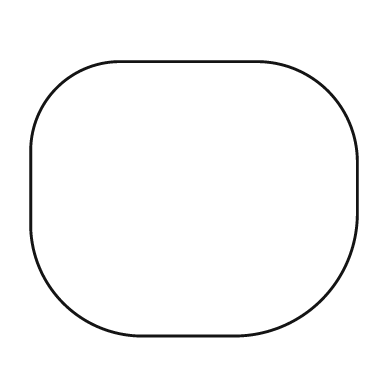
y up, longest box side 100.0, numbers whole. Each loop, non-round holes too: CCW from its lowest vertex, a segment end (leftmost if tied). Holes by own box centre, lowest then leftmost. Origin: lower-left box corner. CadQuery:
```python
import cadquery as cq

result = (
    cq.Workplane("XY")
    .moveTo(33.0, 0.0)
    .lineTo(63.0, 0.0)
    .threePointArc((89.0, 11.0), (100.0, 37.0))
    .lineTo(100.0, 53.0)
    .threePointArc((91.0, 75.0), (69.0, 84.0))
    .lineTo(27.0, 84.0)
    .threePointArc((8.0, 76.0), (0.0, 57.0))
    .lineTo(0.0, 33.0)
    .threePointArc((10.0, 10.0), (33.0, 0.0))
    .close()
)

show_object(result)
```